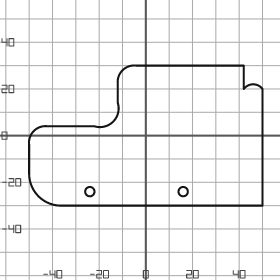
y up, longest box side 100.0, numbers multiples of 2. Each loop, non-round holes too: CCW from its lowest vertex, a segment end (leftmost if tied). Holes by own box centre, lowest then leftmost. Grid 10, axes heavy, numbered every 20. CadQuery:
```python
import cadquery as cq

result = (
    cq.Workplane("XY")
    .moveTo(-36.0, -30.0)
    .lineTo(50.0, -30.0)
    .lineTo(50.0, 20.0)
    .threePointArc((46.0, 22.0), (42.0, 20.0))
    .lineTo(42.0, 30.0)
    .lineTo(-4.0, 30.0)
    .threePointArc((-10.0, 28.0), (-12.0, 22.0))
    .lineTo(-12.0, 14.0)
    .threePointArc((-14.0, 6.0), (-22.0, 4.0))
    .lineTo(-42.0, 4.0)
    .threePointArc((-48.0, 2.0), (-50.0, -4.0))
    .lineTo(-50.0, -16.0)
    .threePointArc((-46.0, -26.0), (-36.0, -30.0))
    .close()
    .moveTo(-24.0, -24.0)
    .circle(2.0)
    .moveTo(16.0, -24.0)
    .circle(2.0)
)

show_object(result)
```